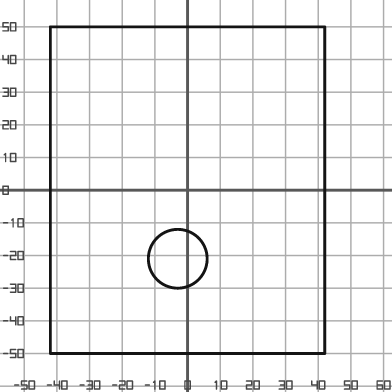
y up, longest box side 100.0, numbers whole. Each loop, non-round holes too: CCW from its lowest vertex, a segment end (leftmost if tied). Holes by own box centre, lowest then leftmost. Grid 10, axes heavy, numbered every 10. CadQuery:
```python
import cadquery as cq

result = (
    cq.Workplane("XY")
    .moveTo(-42.0, -50.0)
    .lineTo(42.0, -50.0)
    .lineTo(42.0, 50.0)
    .lineTo(-42.0, 50.0)
    .close()
    .moveTo(-3.0, -21.0)
    .circle(9.0)
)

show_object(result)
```